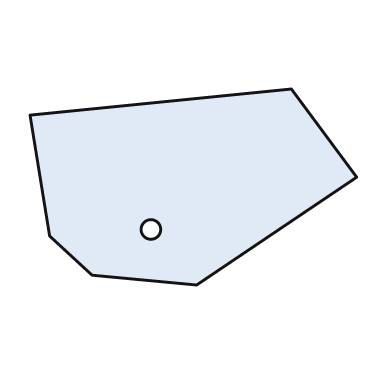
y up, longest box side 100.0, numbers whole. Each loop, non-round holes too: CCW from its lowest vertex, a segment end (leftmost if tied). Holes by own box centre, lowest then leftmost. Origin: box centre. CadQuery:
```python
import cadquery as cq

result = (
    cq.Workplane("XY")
    .moveTo(1.0, -30.0)
    .lineTo(50.0, 3.0)
    .lineTo(30.0, 30.0)
    .lineTo(-50.0, 22.0)
    .lineTo(-44.0, -15.0)
    .lineTo(-31.0, -27.0)
    .close()
    .moveTo(-13.0, -13.0)
    .circle(3.0)
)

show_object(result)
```